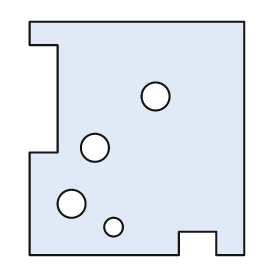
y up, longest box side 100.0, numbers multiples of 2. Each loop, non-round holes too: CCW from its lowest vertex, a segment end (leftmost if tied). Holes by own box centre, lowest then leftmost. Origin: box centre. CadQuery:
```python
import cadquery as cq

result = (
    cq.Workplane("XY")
    .moveTo(-46.0, -50.0)
    .lineTo(18.0, -50.0)
    .lineTo(18.0, -40.0)
    .lineTo(34.0, -40.0)
    .lineTo(34.0, -50.0)
    .lineTo(46.0, -50.0)
    .lineTo(46.0, 50.0)
    .lineTo(-46.0, 50.0)
    .lineTo(-46.0, 40.0)
    .lineTo(-34.0, 40.0)
    .lineTo(-34.0, -6.0)
    .lineTo(-46.0, -6.0)
    .close()
    .moveTo(-10.0, -38.0)
    .circle(4.0)
    .moveTo(-28.0, -28.0)
    .circle(6.0)
    .moveTo(-18.0, -4.0)
    .circle(6.0)
    .moveTo(8.0, 18.0)
    .circle(6.0)
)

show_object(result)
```